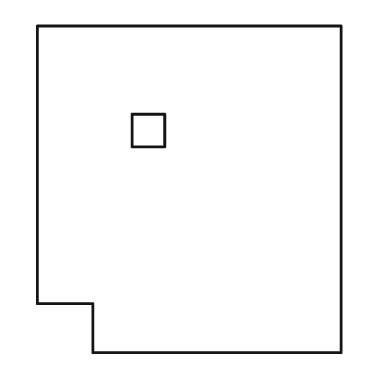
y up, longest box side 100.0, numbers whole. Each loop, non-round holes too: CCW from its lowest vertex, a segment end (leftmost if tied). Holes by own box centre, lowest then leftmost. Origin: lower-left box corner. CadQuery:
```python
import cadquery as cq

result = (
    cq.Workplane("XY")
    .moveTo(17.0, 0.0)
    .lineTo(93.0, 0.0)
    .lineTo(93.0, 100.0)
    .lineTo(0.0, 100.0)
    .lineTo(0.0, 15.0)
    .lineTo(17.0, 15.0)
    .close()
    .moveTo(29.0, 63.0)
    .lineTo(39.0, 63.0)
    .lineTo(39.0, 73.0)
    .lineTo(29.0, 73.0)
    .close()
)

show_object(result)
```